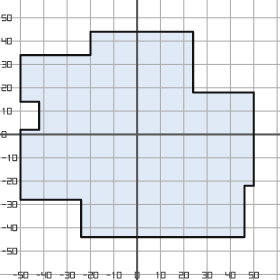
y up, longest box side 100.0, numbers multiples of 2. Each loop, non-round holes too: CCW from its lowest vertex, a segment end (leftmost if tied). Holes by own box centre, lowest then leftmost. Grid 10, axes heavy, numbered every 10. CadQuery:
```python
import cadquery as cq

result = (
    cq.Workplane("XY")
    .moveTo(-24.0, -44.0)
    .lineTo(46.0, -44.0)
    .lineTo(46.0, -22.0)
    .lineTo(50.0, -22.0)
    .lineTo(50.0, 18.0)
    .lineTo(24.0, 18.0)
    .lineTo(24.0, 44.0)
    .lineTo(-20.0, 44.0)
    .lineTo(-20.0, 34.0)
    .lineTo(-50.0, 34.0)
    .lineTo(-50.0, 14.0)
    .lineTo(-42.0, 14.0)
    .lineTo(-42.0, 2.0)
    .lineTo(-50.0, 2.0)
    .lineTo(-50.0, -28.0)
    .lineTo(-24.0, -28.0)
    .close()
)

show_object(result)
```